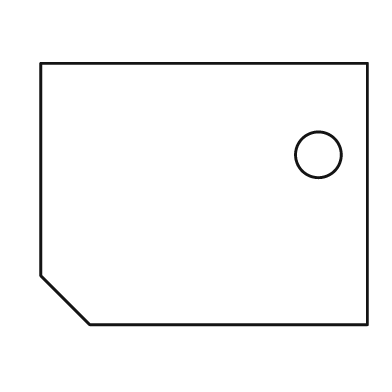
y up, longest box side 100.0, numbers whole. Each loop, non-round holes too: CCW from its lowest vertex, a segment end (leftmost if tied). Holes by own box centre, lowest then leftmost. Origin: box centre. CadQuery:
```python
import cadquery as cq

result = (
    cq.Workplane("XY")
    .moveTo(-35.0, -40.0)
    .lineTo(50.0, -40.0)
    .lineTo(50.0, 40.0)
    .lineTo(-50.0, 40.0)
    .lineTo(-50.0, -25.0)
    .close()
    .moveTo(35.0, 12.0)
    .circle(7.0)
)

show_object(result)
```